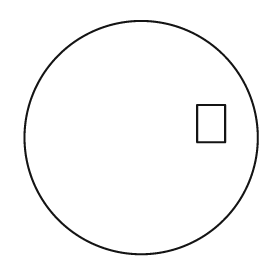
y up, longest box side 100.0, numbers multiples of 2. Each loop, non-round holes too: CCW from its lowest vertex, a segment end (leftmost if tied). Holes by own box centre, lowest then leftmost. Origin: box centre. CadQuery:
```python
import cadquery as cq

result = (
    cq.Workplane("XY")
    .moveTo(0.0, 0.0)
    .circle(50.0)
    .moveTo(24.0, -2.0)
    .lineTo(36.0, -2.0)
    .lineTo(36.0, 14.0)
    .lineTo(24.0, 14.0)
    .close()
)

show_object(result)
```